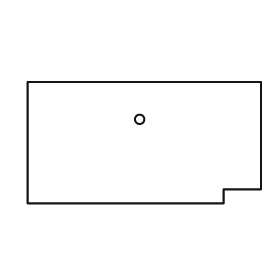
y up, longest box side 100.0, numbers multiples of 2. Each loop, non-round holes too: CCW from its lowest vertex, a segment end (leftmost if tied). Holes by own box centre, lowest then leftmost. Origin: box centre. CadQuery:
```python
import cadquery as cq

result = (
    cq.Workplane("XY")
    .moveTo(-50.0, -26.0)
    .lineTo(34.0, -26.0)
    .lineTo(34.0, -20.0)
    .lineTo(50.0, -20.0)
    .lineTo(50.0, 26.0)
    .lineTo(-50.0, 26.0)
    .close()
    .moveTo(-2.0, 10.0)
    .circle(2.0)
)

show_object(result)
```